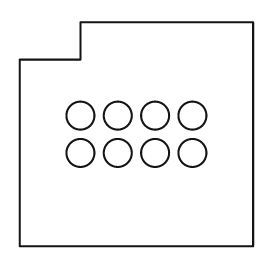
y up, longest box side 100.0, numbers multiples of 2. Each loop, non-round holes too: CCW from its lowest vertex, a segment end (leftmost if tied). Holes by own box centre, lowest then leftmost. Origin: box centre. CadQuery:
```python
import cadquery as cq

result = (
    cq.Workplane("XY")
    .moveTo(-50.0, -48.0)
    .lineTo(50.0, -48.0)
    .lineTo(50.0, 48.0)
    .lineTo(-24.0, 48.0)
    .lineTo(-24.0, 32.0)
    .lineTo(-50.0, 32.0)
    .close()
    .moveTo(-24.0, -8.0)
    .circle(6.0)
    .moveTo(-8.0, -8.0)
    .circle(6.0)
    .moveTo(8.0, -8.0)
    .circle(6.0)
    .moveTo(24.0, -8.0)
    .circle(6.0)
    .moveTo(-24.0, 8.0)
    .circle(6.0)
    .moveTo(-8.0, 8.0)
    .circle(6.0)
    .moveTo(8.0, 8.0)
    .circle(6.0)
    .moveTo(24.0, 8.0)
    .circle(6.0)
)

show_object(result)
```